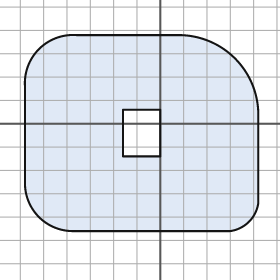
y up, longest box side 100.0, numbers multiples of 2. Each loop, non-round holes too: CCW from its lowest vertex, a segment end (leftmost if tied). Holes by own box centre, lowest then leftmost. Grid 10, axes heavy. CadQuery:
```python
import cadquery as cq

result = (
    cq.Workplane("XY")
    .moveTo(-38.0, -46.0)
    .lineTo(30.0, -46.0)
    .threePointArc((38.0, -42.0), (42.0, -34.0))
    .lineTo(42.0, 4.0)
    .threePointArc((32.0, 28.0), (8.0, 38.0))
    .lineTo(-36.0, 38.0)
    .threePointArc((-52.0, 32.0), (-58.0, 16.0))
    .lineTo(-58.0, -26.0)
    .threePointArc((-52.0, -40.0), (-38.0, -46.0))
    .close()
    .moveTo(-16.0, -14.0)
    .lineTo(0.0, -14.0)
    .lineTo(0.0, 6.0)
    .lineTo(-16.0, 6.0)
    .close()
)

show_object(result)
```